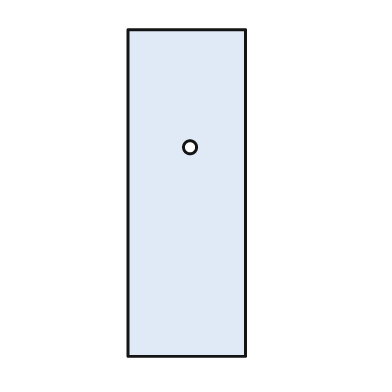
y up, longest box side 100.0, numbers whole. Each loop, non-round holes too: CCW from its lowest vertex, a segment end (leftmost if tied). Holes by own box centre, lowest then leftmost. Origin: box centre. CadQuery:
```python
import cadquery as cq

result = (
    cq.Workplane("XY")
    .moveTo(-18.0, -50.0)
    .lineTo(18.0, -50.0)
    .lineTo(18.0, 50.0)
    .lineTo(-18.0, 50.0)
    .close()
    .moveTo(1.0, 14.0)
    .circle(2.0)
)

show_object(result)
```